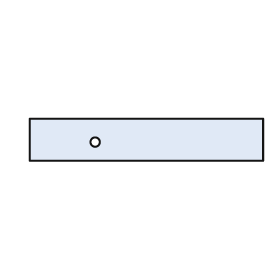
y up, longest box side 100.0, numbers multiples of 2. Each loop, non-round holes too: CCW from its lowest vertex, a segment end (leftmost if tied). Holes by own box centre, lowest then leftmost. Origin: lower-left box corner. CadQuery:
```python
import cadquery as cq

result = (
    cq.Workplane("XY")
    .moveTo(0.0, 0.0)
    .lineTo(100.0, 0.0)
    .lineTo(100.0, 18.0)
    .lineTo(0.0, 18.0)
    .close()
    .moveTo(28.0, 8.0)
    .circle(2.0)
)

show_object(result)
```